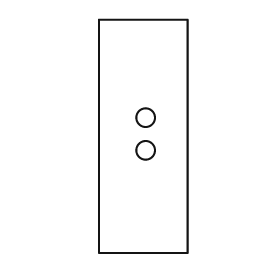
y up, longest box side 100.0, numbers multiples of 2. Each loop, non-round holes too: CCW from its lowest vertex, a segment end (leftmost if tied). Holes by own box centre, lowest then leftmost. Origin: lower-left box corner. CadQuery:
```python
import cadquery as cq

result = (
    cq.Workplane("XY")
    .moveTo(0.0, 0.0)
    .lineTo(38.0, 0.0)
    .lineTo(38.0, 100.0)
    .lineTo(0.0, 100.0)
    .close()
    .moveTo(20.0, 44.0)
    .circle(4.0)
    .moveTo(20.0, 58.0)
    .circle(4.0)
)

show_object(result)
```